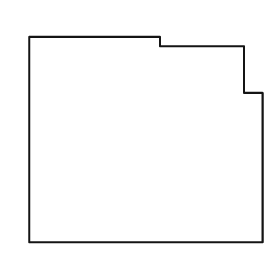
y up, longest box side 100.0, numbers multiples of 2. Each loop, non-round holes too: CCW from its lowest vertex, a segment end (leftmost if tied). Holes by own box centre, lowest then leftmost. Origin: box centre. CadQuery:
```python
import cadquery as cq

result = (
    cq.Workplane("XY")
    .moveTo(-50.0, -44.0)
    .lineTo(50.0, -44.0)
    .lineTo(50.0, 20.0)
    .lineTo(42.0, 20.0)
    .lineTo(42.0, 40.0)
    .lineTo(6.0, 40.0)
    .lineTo(6.0, 44.0)
    .lineTo(-50.0, 44.0)
    .close()
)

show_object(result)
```